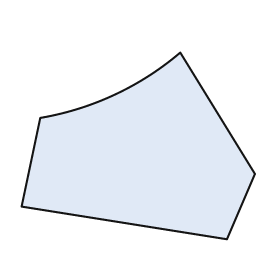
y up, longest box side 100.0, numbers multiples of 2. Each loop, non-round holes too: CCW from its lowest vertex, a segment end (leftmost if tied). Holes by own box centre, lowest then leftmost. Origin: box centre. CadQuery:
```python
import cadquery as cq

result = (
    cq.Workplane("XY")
    .moveTo(38.0, -40.0)
    .lineTo(50.0, -12.0)
    .lineTo(18.0, 40.0)
    .threePointArc((-10.0, 22.0), (-42.0, 12.0))
    .lineTo(-50.0, -26.0)
    .close()
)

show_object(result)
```